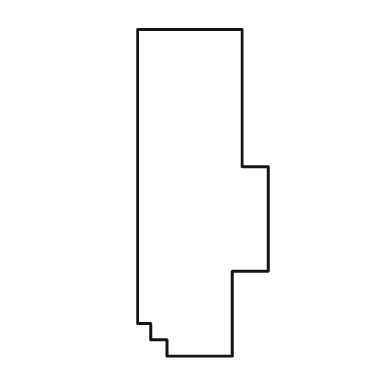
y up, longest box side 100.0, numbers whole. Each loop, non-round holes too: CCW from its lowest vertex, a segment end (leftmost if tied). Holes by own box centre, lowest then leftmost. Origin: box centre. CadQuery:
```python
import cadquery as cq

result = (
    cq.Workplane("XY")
    .moveTo(-11.0, -50.0)
    .lineTo(9.0, -50.0)
    .lineTo(9.0, -24.0)
    .lineTo(20.0, -24.0)
    .lineTo(20.0, 8.0)
    .lineTo(12.0, 8.0)
    .lineTo(12.0, 50.0)
    .lineTo(-20.0, 50.0)
    .lineTo(-20.0, -40.0)
    .lineTo(-16.0, -40.0)
    .lineTo(-16.0, -45.0)
    .lineTo(-11.0, -45.0)
    .close()
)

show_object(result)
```